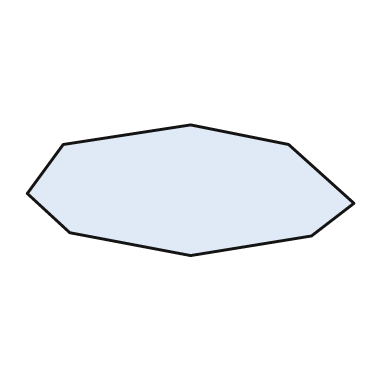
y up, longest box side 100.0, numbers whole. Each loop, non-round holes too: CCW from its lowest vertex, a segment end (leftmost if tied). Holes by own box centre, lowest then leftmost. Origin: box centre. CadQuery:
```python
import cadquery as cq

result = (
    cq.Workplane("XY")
    .moveTo(0.0, -20.0)
    .lineTo(37.0, -14.0)
    .lineTo(50.0, -4.0)
    .lineTo(30.0, 14.0)
    .lineTo(0.0, 20.0)
    .lineTo(-39.0, 14.0)
    .lineTo(-50.0, -1.0)
    .lineTo(-37.0, -13.0)
    .close()
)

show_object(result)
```